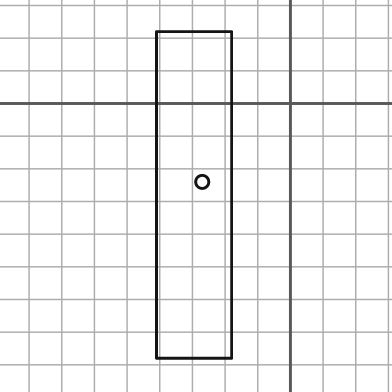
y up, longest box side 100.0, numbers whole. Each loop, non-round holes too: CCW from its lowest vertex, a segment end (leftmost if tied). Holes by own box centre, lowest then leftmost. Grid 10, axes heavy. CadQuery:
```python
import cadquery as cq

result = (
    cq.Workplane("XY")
    .moveTo(-41.0, -78.0)
    .lineTo(-18.0, -78.0)
    .lineTo(-18.0, 22.0)
    .lineTo(-41.0, 22.0)
    .close()
    .moveTo(-27.0, -24.0)
    .circle(2.0)
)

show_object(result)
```